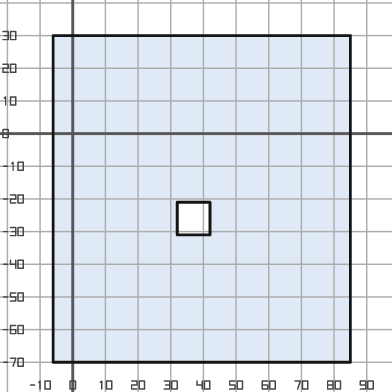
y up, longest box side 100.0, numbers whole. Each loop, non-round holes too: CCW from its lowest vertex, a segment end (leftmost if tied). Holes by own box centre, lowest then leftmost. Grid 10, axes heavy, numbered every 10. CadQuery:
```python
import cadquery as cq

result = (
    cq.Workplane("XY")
    .moveTo(-6.0, -70.0)
    .lineTo(85.0, -70.0)
    .lineTo(85.0, 30.0)
    .lineTo(-6.0, 30.0)
    .close()
    .moveTo(32.0, -31.0)
    .lineTo(42.0, -31.0)
    .lineTo(42.0, -21.0)
    .lineTo(32.0, -21.0)
    .close()
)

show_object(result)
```